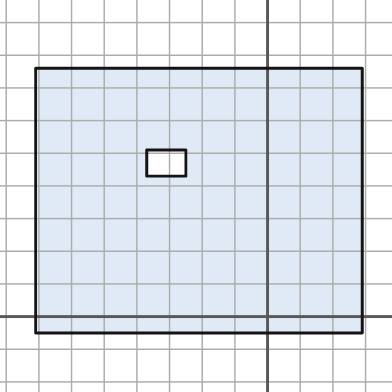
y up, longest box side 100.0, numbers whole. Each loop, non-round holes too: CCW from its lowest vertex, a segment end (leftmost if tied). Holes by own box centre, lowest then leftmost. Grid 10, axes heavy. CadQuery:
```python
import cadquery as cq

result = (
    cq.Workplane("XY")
    .moveTo(-71.0, -5.0)
    .lineTo(29.0, -5.0)
    .lineTo(29.0, 76.0)
    .lineTo(-71.0, 76.0)
    .close()
    .moveTo(-37.0, 43.0)
    .lineTo(-25.0, 43.0)
    .lineTo(-25.0, 51.0)
    .lineTo(-37.0, 51.0)
    .close()
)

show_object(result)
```